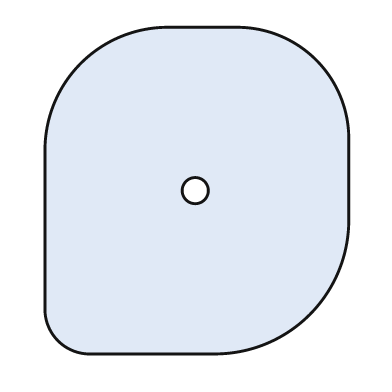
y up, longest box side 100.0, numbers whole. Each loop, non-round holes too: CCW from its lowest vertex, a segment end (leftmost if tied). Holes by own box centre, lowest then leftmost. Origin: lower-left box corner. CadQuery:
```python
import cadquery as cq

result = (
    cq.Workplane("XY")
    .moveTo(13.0, 0.0)
    .lineTo(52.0, 0.0)
    .threePointArc((81.0, 12.0), (93.0, 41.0))
    .lineTo(93.0, 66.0)
    .threePointArc((83.0, 90.0), (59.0, 100.0))
    .lineTo(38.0, 100.0)
    .threePointArc((11.0, 89.0), (0.0, 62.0))
    .lineTo(0.0, 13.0)
    .threePointArc((4.0, 4.0), (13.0, 0.0))
    .close()
    .moveTo(46.0, 50.0)
    .circle(4.0)
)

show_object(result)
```